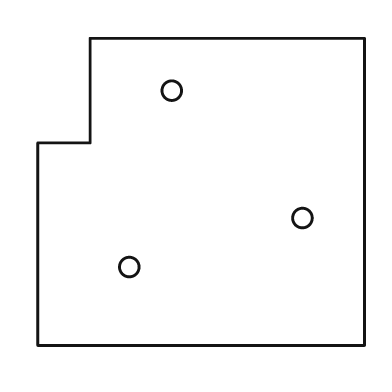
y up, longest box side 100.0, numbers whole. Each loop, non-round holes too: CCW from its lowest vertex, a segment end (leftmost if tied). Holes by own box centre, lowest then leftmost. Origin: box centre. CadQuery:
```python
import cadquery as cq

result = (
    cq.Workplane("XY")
    .moveTo(-50.0, -47.0)
    .lineTo(50.0, -47.0)
    .lineTo(50.0, 47.0)
    .lineTo(-34.0, 47.0)
    .lineTo(-34.0, 15.0)
    .lineTo(-50.0, 15.0)
    .close()
    .moveTo(-22.0, -23.0)
    .circle(3.0)
    .moveTo(31.0, -8.0)
    .circle(3.0)
    .moveTo(-9.0, 31.0)
    .circle(3.0)
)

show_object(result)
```